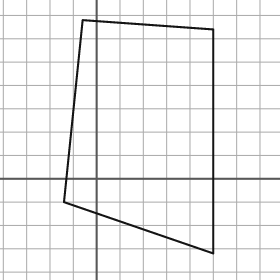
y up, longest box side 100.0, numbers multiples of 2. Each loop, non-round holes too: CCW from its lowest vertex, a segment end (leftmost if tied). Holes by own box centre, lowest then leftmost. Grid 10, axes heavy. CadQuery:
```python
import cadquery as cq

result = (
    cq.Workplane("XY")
    .moveTo(50.0, -32.0)
    .lineTo(50.0, 64.0)
    .lineTo(-6.0, 68.0)
    .lineTo(-14.0, -10.0)
    .close()
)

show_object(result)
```